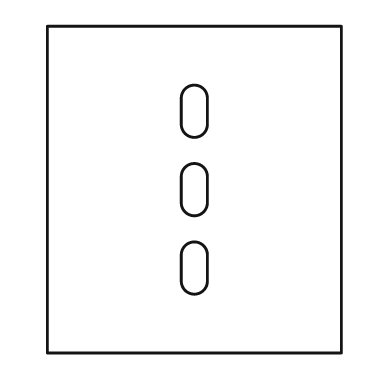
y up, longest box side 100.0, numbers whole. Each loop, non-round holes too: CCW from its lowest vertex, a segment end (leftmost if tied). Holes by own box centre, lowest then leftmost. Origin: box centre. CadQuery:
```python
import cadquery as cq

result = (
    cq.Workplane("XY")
    .moveTo(-45.0, -50.0)
    .lineTo(45.0, -50.0)
    .lineTo(45.0, 50.0)
    .lineTo(-45.0, 50.0)
    .close()
    .moveTo(-4.0, -28.0)
    .threePointArc((0.0, -32.0), (4.0, -28.0))
    .lineTo(4.0, -20.0)
    .threePointArc((0.0, -16.0), (-4.0, -20.0))
    .close()
    .moveTo(-4.0, -4.0)
    .threePointArc((0.0, -8.0), (4.0, -4.0))
    .lineTo(4.0, 4.0)
    .threePointArc((0.0, 8.0), (-4.0, 4.0))
    .close()
    .moveTo(-4.0, 20.0)
    .threePointArc((0.0, 16.0), (4.0, 20.0))
    .lineTo(4.0, 28.0)
    .threePointArc((0.0, 32.0), (-4.0, 28.0))
    .close()
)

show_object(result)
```